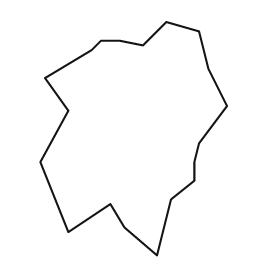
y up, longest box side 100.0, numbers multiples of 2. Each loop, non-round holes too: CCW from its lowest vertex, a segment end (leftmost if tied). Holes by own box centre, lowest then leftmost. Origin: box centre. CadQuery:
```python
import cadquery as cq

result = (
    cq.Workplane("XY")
    .moveTo(10.0, -50.0)
    .lineTo(16.0, -26.0)
    .lineTo(26.0, -18.0)
    .lineTo(26.0, -10.0)
    .lineTo(28.0, -2.0)
    .lineTo(40.0, 14.0)
    .lineTo(32.0, 30.0)
    .lineTo(28.0, 46.0)
    .lineTo(14.0, 50.0)
    .lineTo(4.0, 40.0)
    .lineTo(-6.0, 42.0)
    .lineTo(-14.0, 42.0)
    .lineTo(-18.0, 38.0)
    .lineTo(-38.0, 26.0)
    .lineTo(-28.0, 12.0)
    .lineTo(-40.0, -10.0)
    .lineTo(-28.0, -40.0)
    .lineTo(-10.0, -28.0)
    .lineTo(-4.0, -38.0)
    .close()
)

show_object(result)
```